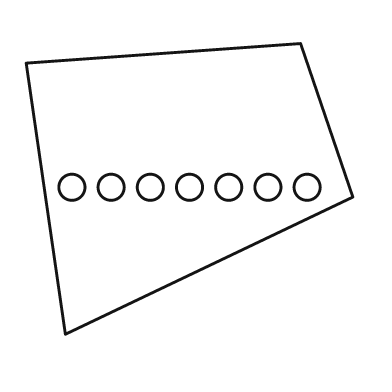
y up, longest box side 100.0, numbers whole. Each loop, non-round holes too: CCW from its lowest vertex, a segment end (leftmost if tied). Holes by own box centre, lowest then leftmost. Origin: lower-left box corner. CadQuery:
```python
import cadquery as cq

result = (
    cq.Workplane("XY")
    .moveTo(12.0, 0.0)
    .lineTo(100.0, 42.0)
    .lineTo(84.0, 89.0)
    .lineTo(0.0, 83.0)
    .close()
    .moveTo(14.0, 45.0)
    .circle(4.0)
    .moveTo(26.0, 45.0)
    .circle(4.0)
    .moveTo(38.0, 45.0)
    .circle(4.0)
    .moveTo(50.0, 45.0)
    .circle(4.0)
    .moveTo(62.0, 45.0)
    .circle(4.0)
    .moveTo(74.0, 45.0)
    .circle(4.0)
    .moveTo(86.0, 45.0)
    .circle(4.0)
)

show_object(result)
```